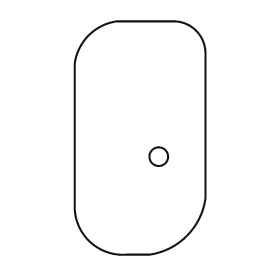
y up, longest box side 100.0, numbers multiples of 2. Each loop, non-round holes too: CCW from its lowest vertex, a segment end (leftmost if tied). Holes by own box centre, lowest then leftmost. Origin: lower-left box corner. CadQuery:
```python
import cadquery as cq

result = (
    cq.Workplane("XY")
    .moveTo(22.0, 0.0)
    .lineTo(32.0, 0.0)
    .threePointArc((48.0, 8.0), (56.0, 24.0))
    .lineTo(56.0, 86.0)
    .threePointArc((52.0, 96.0), (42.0, 100.0))
    .lineTo(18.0, 100.0)
    .threePointArc((6.0, 94.0), (0.0, 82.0))
    .lineTo(0.0, 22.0)
    .threePointArc((6.0, 6.0), (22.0, 0.0))
    .close()
    .moveTo(36.0, 42.0)
    .circle(4.0)
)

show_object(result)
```